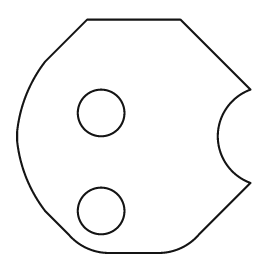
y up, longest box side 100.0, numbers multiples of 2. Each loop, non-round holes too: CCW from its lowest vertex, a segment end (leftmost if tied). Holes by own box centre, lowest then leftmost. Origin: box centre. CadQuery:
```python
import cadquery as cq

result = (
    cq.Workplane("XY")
    .moveTo(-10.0, -50.0)
    .lineTo(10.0, -50.0)
    .threePointArc((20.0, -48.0), (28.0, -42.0))
    .lineTo(50.0, -20.0)
    .threePointArc((36.0, 0.0), (50.0, 20.0))
    .lineTo(20.0, 50.0)
    .lineTo(-20.0, 50.0)
    .lineTo(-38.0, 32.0)
    .threePointArc((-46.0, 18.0), (-50.0, 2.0))
    .lineTo(-50.0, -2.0)
    .threePointArc((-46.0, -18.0), (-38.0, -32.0))
    .lineTo(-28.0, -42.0)
    .threePointArc((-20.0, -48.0), (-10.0, -50.0))
    .close()
    .moveTo(-14.0, -32.0)
    .circle(10.0)
    .moveTo(-14.0, 10.0)
    .circle(10.0)
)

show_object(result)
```